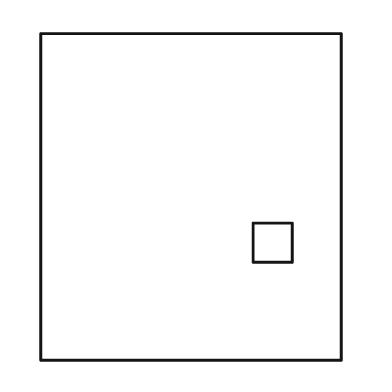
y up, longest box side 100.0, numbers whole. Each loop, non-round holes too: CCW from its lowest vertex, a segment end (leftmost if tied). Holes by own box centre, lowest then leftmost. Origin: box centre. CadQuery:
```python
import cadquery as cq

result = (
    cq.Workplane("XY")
    .moveTo(-46.0, -50.0)
    .lineTo(46.0, -50.0)
    .lineTo(46.0, 50.0)
    .lineTo(-46.0, 50.0)
    .close()
    .moveTo(19.0, -20.0)
    .lineTo(31.0, -20.0)
    .lineTo(31.0, -8.0)
    .lineTo(19.0, -8.0)
    .close()
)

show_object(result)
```